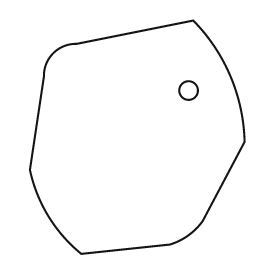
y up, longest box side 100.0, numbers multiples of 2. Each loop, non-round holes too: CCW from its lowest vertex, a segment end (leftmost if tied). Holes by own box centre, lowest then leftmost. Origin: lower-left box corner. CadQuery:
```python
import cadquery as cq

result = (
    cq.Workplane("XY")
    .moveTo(22.0, 0.0)
    .lineTo(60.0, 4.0)
    .threePointArc((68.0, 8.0), (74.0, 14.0))
    .lineTo(92.0, 48.0)
    .threePointArc((86.0, 76.0), (70.0, 100.0))
    .lineTo(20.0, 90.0)
    .threePointArc((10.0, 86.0), (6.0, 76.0))
    .lineTo(0.0, 36.0)
    .threePointArc((8.0, 16.0), (22.0, 0.0))
    .close()
    .moveTo(68.0, 70.0)
    .circle(4.0)
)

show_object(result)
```